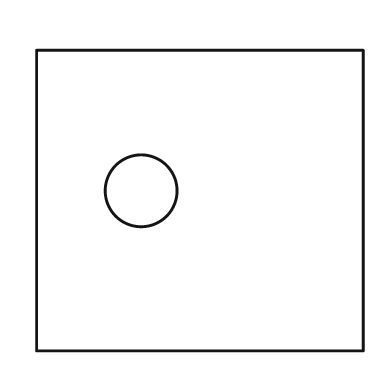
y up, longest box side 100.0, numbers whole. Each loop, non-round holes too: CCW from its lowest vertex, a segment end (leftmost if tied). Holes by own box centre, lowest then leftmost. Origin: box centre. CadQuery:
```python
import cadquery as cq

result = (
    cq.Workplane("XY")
    .moveTo(-50.0, -46.0)
    .lineTo(50.0, -46.0)
    .lineTo(50.0, 46.0)
    .lineTo(-50.0, 46.0)
    .close()
    .moveTo(-18.0, 3.0)
    .circle(11.0)
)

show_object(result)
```